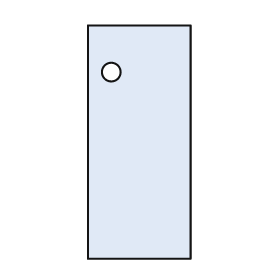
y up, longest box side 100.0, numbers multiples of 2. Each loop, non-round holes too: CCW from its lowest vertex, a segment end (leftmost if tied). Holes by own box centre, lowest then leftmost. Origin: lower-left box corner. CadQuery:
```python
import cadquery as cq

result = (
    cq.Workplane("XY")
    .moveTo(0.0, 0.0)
    .lineTo(44.0, 0.0)
    .lineTo(44.0, 100.0)
    .lineTo(0.0, 100.0)
    .close()
    .moveTo(10.0, 80.0)
    .circle(4.0)
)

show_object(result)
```